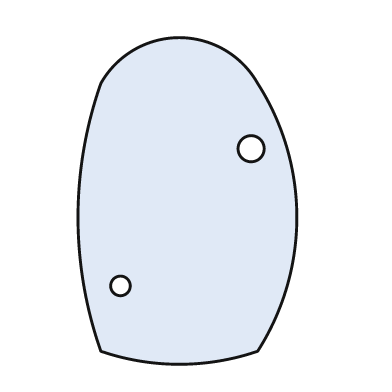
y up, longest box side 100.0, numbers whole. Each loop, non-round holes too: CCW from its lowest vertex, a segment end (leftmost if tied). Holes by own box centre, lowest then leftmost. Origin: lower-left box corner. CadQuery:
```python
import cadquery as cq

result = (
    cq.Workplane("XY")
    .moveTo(7.0, 4.0)
    .threePointArc((31.0, 0.0), (55.0, 4.0))
    .threePointArc((67.0, 45.0), (55.0, 86.0))
    .threePointArc((31.0, 100.0), (7.0, 86.0))
    .threePointArc((0.0, 45.0), (7.0, 4.0))
    .close()
    .moveTo(13.0, 24.0)
    .circle(3.0)
    .moveTo(53.0, 66.0)
    .circle(4.0)
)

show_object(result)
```